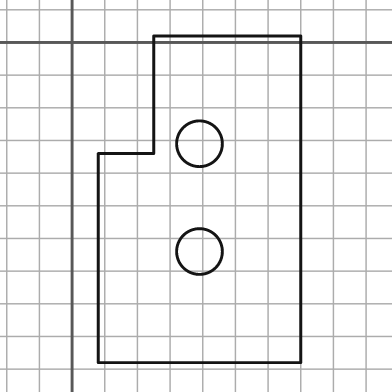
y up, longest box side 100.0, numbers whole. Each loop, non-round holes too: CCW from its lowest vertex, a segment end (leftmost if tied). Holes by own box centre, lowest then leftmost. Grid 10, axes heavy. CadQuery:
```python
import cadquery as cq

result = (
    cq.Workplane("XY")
    .moveTo(8.0, -98.0)
    .lineTo(70.0, -98.0)
    .lineTo(70.0, 2.0)
    .lineTo(25.0, 2.0)
    .lineTo(25.0, -34.0)
    .lineTo(8.0, -34.0)
    .close()
    .moveTo(39.0, -64.0)
    .circle(7.0)
    .moveTo(39.0, -31.0)
    .circle(7.0)
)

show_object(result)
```